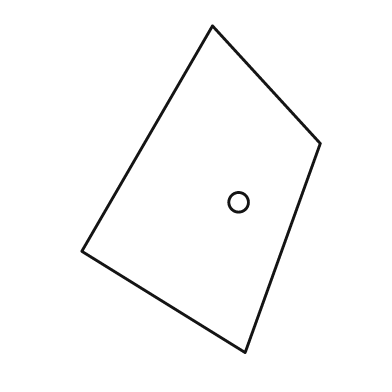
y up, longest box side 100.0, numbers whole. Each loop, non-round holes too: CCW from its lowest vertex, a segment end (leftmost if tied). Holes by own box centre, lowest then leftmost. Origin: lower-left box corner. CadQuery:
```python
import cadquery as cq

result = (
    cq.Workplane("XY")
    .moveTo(50.0, 0.0)
    .lineTo(73.0, 64.0)
    .lineTo(40.0, 100.0)
    .lineTo(0.0, 31.0)
    .close()
    .moveTo(48.0, 46.0)
    .circle(3.0)
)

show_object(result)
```